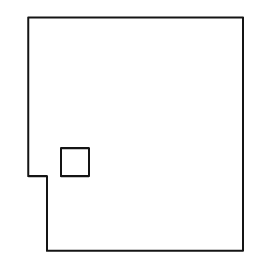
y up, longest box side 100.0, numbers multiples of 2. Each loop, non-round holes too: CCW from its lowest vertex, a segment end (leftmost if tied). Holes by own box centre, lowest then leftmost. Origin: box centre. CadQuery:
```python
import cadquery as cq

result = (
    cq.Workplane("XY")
    .moveTo(-38.0, -50.0)
    .lineTo(46.0, -50.0)
    .lineTo(46.0, 50.0)
    .lineTo(-46.0, 50.0)
    .lineTo(-46.0, -18.0)
    .lineTo(-38.0, -18.0)
    .close()
    .moveTo(-32.0, -18.0)
    .lineTo(-20.0, -18.0)
    .lineTo(-20.0, -6.0)
    .lineTo(-32.0, -6.0)
    .close()
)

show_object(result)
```